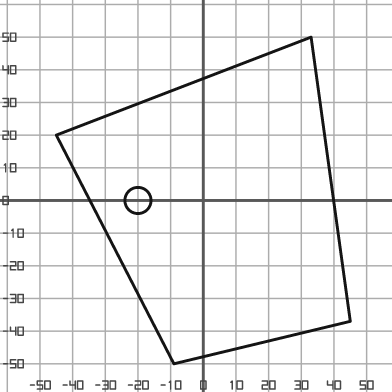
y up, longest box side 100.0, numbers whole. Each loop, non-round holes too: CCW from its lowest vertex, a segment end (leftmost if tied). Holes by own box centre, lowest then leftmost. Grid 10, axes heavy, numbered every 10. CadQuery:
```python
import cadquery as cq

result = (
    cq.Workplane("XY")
    .moveTo(-9.0, -50.0)
    .lineTo(45.0, -37.0)
    .lineTo(33.0, 50.0)
    .lineTo(-45.0, 20.0)
    .close()
    .moveTo(-20.0, 0.0)
    .circle(4.0)
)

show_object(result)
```